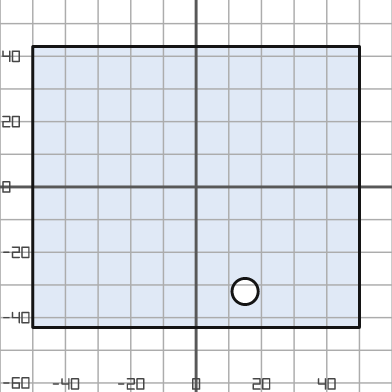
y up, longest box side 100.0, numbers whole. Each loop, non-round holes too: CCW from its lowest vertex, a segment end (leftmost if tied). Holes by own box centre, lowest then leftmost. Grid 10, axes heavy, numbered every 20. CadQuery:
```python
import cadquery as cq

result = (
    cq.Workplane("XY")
    .moveTo(-50.0, -43.0)
    .lineTo(50.0, -43.0)
    .lineTo(50.0, 43.0)
    .lineTo(-50.0, 43.0)
    .close()
    .moveTo(15.0, -32.0)
    .circle(4.0)
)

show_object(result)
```